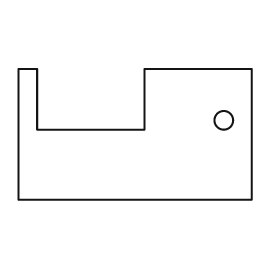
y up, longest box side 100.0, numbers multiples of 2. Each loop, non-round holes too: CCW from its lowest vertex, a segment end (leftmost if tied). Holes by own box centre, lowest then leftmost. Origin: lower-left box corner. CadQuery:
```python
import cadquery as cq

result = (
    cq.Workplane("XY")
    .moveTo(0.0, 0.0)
    .lineTo(100.0, 0.0)
    .lineTo(100.0, 56.0)
    .lineTo(54.0, 56.0)
    .lineTo(54.0, 30.0)
    .lineTo(8.0, 30.0)
    .lineTo(8.0, 56.0)
    .lineTo(0.0, 56.0)
    .close()
    .moveTo(88.0, 34.0)
    .circle(4.0)
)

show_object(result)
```